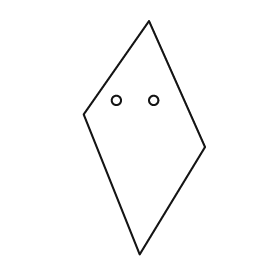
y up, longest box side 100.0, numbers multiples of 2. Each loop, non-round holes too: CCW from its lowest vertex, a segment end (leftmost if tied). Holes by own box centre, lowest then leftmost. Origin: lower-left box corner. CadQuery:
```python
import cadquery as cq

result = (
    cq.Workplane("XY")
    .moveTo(24.0, 0.0)
    .lineTo(52.0, 46.0)
    .lineTo(28.0, 100.0)
    .lineTo(0.0, 60.0)
    .close()
    .moveTo(14.0, 66.0)
    .circle(2.0)
    .moveTo(30.0, 66.0)
    .circle(2.0)
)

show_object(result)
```